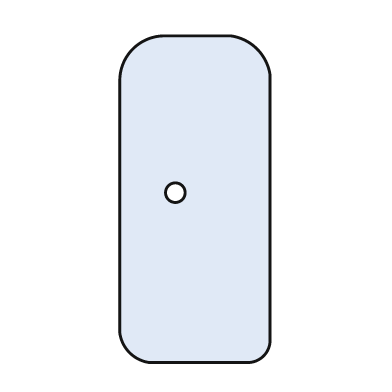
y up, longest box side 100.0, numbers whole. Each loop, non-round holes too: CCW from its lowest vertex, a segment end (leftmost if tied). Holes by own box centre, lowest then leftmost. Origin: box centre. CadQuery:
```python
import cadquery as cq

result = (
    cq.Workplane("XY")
    .moveTo(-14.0, -50.0)
    .lineTo(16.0, -50.0)
    .threePointArc((21.0, -48.0), (23.0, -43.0))
    .lineTo(23.0, 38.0)
    .threePointArc((19.0, 46.0), (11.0, 50.0))
    .lineTo(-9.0, 50.0)
    .threePointArc((-19.0, 46.0), (-23.0, 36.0))
    .lineTo(-23.0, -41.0)
    .threePointArc((-20.0, -47.0), (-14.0, -50.0))
    .close()
    .moveTo(-6.0, 2.0)
    .circle(3.0)
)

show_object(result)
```